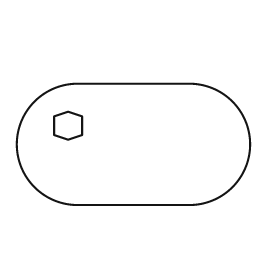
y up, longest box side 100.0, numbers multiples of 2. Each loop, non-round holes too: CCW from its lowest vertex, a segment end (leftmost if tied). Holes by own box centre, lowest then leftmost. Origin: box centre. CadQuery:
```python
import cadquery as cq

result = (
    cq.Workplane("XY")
    .moveTo(-24.0, -26.0)
    .lineTo(24.0, -26.0)
    .threePointArc((50.0, 0.0), (24.0, 26.0))
    .lineTo(-24.0, 26.0)
    .threePointArc((-50.0, 0.0), (-24.0, -26.0))
    .close()
    .moveTo(-28.0, 2.0)
    .lineTo(-22.0, 4.0)
    .lineTo(-22.0, 12.0)
    .lineTo(-28.0, 14.0)
    .lineTo(-34.0, 12.0)
    .lineTo(-34.0, 4.0)
    .close()
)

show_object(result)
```